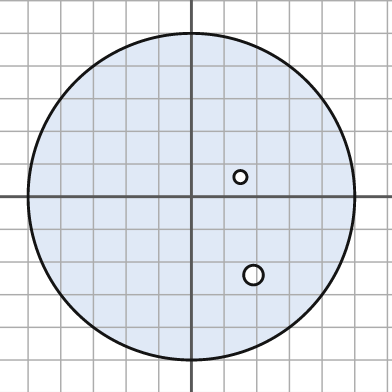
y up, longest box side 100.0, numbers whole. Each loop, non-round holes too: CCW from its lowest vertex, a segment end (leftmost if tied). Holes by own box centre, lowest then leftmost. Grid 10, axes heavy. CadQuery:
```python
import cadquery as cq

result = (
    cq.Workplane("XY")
    .moveTo(0.0, 0.0)
    .circle(50.0)
    .moveTo(19.0, -24.0)
    .circle(3.0)
    .moveTo(15.0, 6.0)
    .circle(2.0)
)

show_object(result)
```